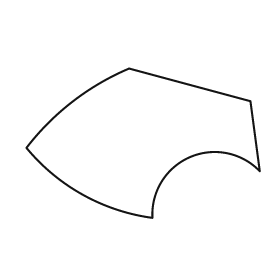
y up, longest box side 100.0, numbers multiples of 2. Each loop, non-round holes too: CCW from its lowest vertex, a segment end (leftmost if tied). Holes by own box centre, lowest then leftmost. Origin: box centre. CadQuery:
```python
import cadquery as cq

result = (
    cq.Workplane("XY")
    .moveTo(4.0, -32.0)
    .threePointArc((20.0, -6.0), (50.0, -12.0))
    .lineTo(46.0, 18.0)
    .lineTo(-6.0, 32.0)
    .threePointArc((-30.0, 18.0), (-50.0, -2.0))
    .threePointArc((-26.0, -22.0), (4.0, -32.0))
    .close()
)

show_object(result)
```